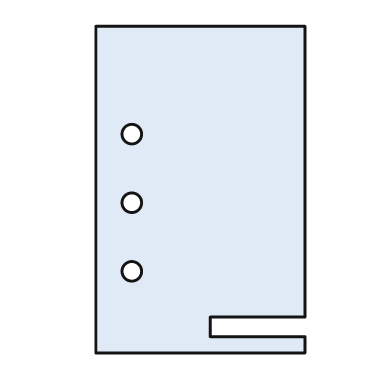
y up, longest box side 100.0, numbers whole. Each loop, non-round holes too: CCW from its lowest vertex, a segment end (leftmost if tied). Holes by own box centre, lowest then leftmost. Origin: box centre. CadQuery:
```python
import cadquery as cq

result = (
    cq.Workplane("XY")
    .moveTo(-32.0, -50.0)
    .lineTo(32.0, -50.0)
    .lineTo(32.0, -45.0)
    .lineTo(3.0, -45.0)
    .lineTo(3.0, -39.0)
    .lineTo(32.0, -39.0)
    .lineTo(32.0, 50.0)
    .lineTo(-32.0, 50.0)
    .close()
    .moveTo(-21.0, -25.0)
    .circle(3.0)
    .moveTo(-21.0, -4.0)
    .circle(3.0)
    .moveTo(-21.0, 17.0)
    .circle(3.0)
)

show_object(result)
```